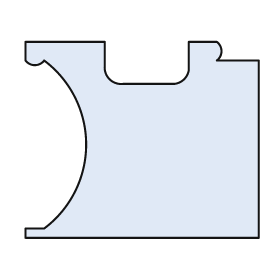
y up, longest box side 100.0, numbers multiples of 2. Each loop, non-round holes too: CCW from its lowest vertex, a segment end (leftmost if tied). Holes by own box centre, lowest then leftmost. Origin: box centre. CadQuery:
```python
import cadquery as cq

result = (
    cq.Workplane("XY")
    .moveTo(-50.0, -42.0)
    .lineTo(50.0, -42.0)
    .lineTo(50.0, 34.0)
    .lineTo(32.0, 34.0)
    .threePointArc((34.0, 38.0), (32.0, 42.0))
    .lineTo(20.0, 42.0)
    .lineTo(20.0, 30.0)
    .threePointArc((18.0, 26.0), (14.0, 24.0))
    .lineTo(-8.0, 24.0)
    .threePointArc((-14.0, 26.0), (-16.0, 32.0))
    .lineTo(-16.0, 42.0)
    .lineTo(-50.0, 42.0)
    .lineTo(-50.0, 34.0)
    .threePointArc((-46.0, 32.0), (-42.0, 34.0))
    .threePointArc((-24.0, -2.0), (-42.0, -38.0))
    .lineTo(-50.0, -38.0)
    .close()
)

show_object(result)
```